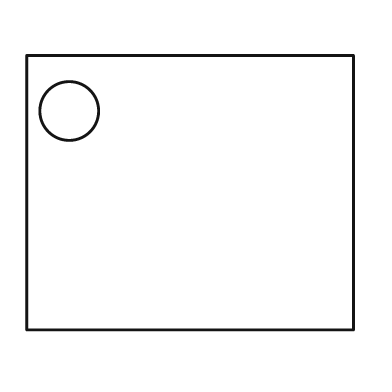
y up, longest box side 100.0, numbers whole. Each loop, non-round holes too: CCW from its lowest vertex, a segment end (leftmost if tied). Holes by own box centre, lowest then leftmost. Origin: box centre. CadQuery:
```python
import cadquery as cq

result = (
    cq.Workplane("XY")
    .moveTo(-50.0, -42.0)
    .lineTo(50.0, -42.0)
    .lineTo(50.0, 42.0)
    .lineTo(-50.0, 42.0)
    .close()
    .moveTo(-37.0, 25.0)
    .circle(9.0)
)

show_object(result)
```